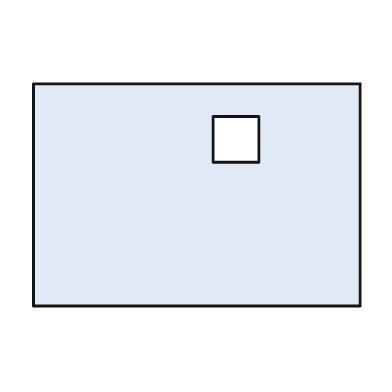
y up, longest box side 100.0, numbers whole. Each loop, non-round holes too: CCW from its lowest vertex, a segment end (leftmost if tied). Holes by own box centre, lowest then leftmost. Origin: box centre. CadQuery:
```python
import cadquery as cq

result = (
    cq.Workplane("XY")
    .moveTo(-50.0, -34.0)
    .lineTo(50.0, -34.0)
    .lineTo(50.0, 34.0)
    .lineTo(-50.0, 34.0)
    .close()
    .moveTo(5.0, 10.0)
    .lineTo(19.0, 10.0)
    .lineTo(19.0, 24.0)
    .lineTo(5.0, 24.0)
    .close()
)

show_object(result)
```